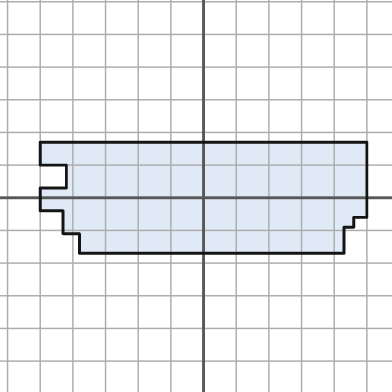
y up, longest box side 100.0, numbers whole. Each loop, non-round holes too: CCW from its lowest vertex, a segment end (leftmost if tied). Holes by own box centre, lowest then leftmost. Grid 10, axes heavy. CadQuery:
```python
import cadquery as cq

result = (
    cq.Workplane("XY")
    .moveTo(-38.0, -17.0)
    .lineTo(43.0, -17.0)
    .lineTo(43.0, -9.0)
    .lineTo(46.0, -9.0)
    .lineTo(46.0, -6.0)
    .lineTo(50.0, -6.0)
    .lineTo(50.0, 17.0)
    .lineTo(-50.0, 17.0)
    .lineTo(-50.0, 10.0)
    .lineTo(-42.0, 10.0)
    .lineTo(-42.0, 3.0)
    .lineTo(-50.0, 3.0)
    .lineTo(-50.0, -4.0)
    .lineTo(-43.0, -4.0)
    .lineTo(-43.0, -11.0)
    .lineTo(-38.0, -11.0)
    .close()
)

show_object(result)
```